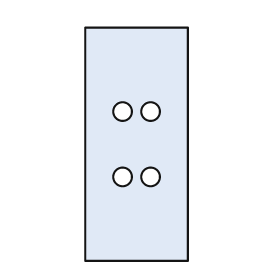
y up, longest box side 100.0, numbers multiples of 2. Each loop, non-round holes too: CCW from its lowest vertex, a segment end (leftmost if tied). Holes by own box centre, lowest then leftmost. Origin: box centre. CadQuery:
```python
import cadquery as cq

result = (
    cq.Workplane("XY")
    .moveTo(-22.0, -50.0)
    .lineTo(22.0, -50.0)
    .lineTo(22.0, 50.0)
    .lineTo(-22.0, 50.0)
    .close()
    .moveTo(-6.0, -14.0)
    .circle(4.0)
    .moveTo(6.0, -14.0)
    .circle(4.0)
    .moveTo(-6.0, 14.0)
    .circle(4.0)
    .moveTo(6.0, 14.0)
    .circle(4.0)
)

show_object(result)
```